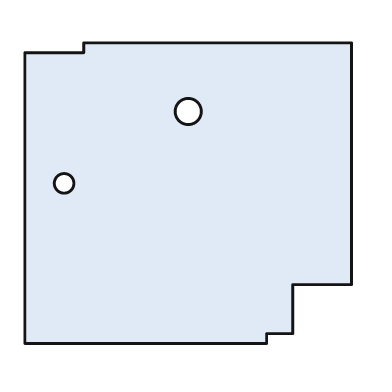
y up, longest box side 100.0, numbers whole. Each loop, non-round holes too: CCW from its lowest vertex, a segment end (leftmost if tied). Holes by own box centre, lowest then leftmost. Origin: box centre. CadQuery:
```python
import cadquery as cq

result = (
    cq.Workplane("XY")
    .moveTo(-50.0, -46.0)
    .lineTo(24.0, -46.0)
    .lineTo(24.0, -43.0)
    .lineTo(32.0, -43.0)
    .lineTo(32.0, -28.0)
    .lineTo(50.0, -28.0)
    .lineTo(50.0, 46.0)
    .lineTo(-32.0, 46.0)
    .lineTo(-32.0, 43.0)
    .lineTo(-50.0, 43.0)
    .close()
    .moveTo(-38.0, 3.0)
    .circle(3.0)
    .moveTo(0.0, 25.0)
    .circle(4.0)
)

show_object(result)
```